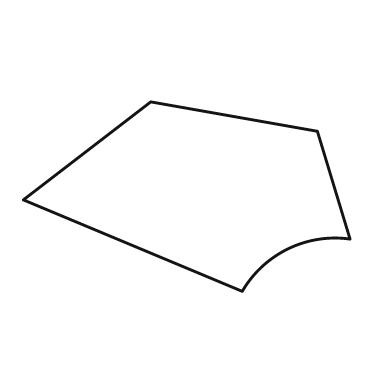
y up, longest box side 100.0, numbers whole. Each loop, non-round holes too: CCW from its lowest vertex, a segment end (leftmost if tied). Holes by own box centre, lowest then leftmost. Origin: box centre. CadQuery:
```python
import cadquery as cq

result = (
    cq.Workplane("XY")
    .moveTo(17.0, -29.0)
    .threePointArc((31.0, -16.0), (50.0, -13.0))
    .lineTo(40.0, 20.0)
    .lineTo(-11.0, 29.0)
    .lineTo(-50.0, -1.0)
    .close()
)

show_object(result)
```